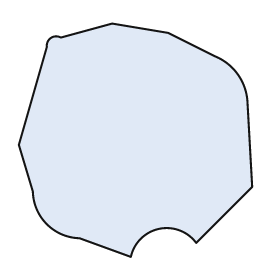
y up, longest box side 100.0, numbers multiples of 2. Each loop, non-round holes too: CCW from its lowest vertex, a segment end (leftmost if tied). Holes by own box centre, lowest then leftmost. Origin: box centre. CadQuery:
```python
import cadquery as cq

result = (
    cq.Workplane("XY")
    .moveTo(-2.0, -50.0)
    .threePointArc((10.0, -38.0), (26.0, -44.0))
    .lineTo(50.0, -20.0)
    .lineTo(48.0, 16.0)
    .threePointArc((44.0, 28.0), (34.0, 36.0))
    .lineTo(14.0, 46.0)
    .lineTo(-10.0, 50.0)
    .lineTo(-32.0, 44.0)
    .threePointArc((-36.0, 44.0), (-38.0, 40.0))
    .lineTo(-50.0, -2.0)
    .lineTo(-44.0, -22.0)
    .threePointArc((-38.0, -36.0), (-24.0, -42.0))
    .close()
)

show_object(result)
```